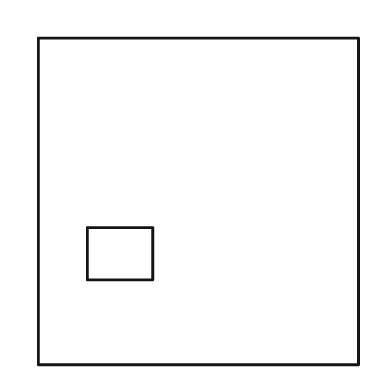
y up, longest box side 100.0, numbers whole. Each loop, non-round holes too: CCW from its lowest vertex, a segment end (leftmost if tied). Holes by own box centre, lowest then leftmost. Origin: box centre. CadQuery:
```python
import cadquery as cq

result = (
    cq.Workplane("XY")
    .moveTo(-49.0, -50.0)
    .lineTo(49.0, -50.0)
    .lineTo(49.0, 50.0)
    .lineTo(-49.0, 50.0)
    .close()
    .moveTo(-34.0, -24.0)
    .lineTo(-14.0, -24.0)
    .lineTo(-14.0, -8.0)
    .lineTo(-34.0, -8.0)
    .close()
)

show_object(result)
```